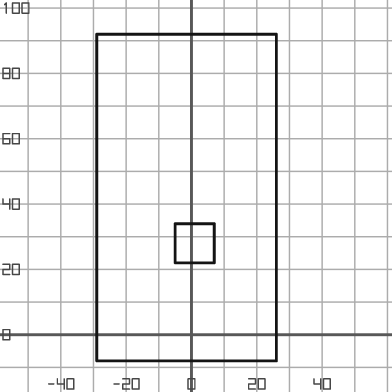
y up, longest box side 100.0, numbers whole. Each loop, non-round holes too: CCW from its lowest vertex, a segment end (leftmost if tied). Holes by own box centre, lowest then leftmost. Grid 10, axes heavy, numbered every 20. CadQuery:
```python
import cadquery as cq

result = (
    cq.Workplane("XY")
    .moveTo(-29.0, -8.0)
    .lineTo(26.0, -8.0)
    .lineTo(26.0, 92.0)
    .lineTo(-29.0, 92.0)
    .close()
    .moveTo(-5.0, 22.0)
    .lineTo(7.0, 22.0)
    .lineTo(7.0, 34.0)
    .lineTo(-5.0, 34.0)
    .close()
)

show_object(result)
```